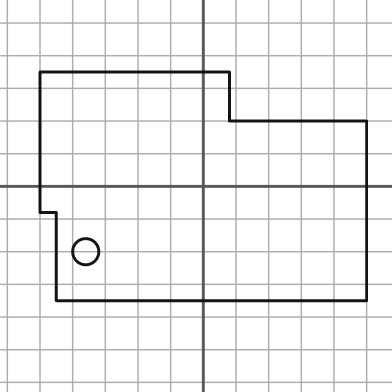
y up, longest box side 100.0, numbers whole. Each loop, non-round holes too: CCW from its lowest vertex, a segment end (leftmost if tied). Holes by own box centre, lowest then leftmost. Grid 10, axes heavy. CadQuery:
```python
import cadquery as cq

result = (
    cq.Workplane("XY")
    .moveTo(-45.0, -35.0)
    .lineTo(50.0, -35.0)
    .lineTo(50.0, 20.0)
    .lineTo(8.0, 20.0)
    .lineTo(8.0, 35.0)
    .lineTo(-50.0, 35.0)
    .lineTo(-50.0, -8.0)
    .lineTo(-45.0, -8.0)
    .close()
    .moveTo(-36.0, -20.0)
    .circle(4.0)
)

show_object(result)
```